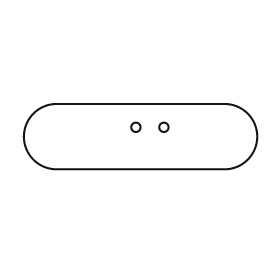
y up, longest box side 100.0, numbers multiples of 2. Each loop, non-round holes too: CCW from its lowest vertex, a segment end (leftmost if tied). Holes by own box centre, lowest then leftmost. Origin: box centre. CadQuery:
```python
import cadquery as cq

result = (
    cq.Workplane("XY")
    .moveTo(-36.0, -14.0)
    .lineTo(36.0, -14.0)
    .threePointArc((50.0, 0.0), (36.0, 14.0))
    .lineTo(-36.0, 14.0)
    .threePointArc((-50.0, 0.0), (-36.0, -14.0))
    .close()
    .moveTo(-2.0, 4.0)
    .circle(2.0)
    .moveTo(10.0, 4.0)
    .circle(2.0)
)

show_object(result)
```